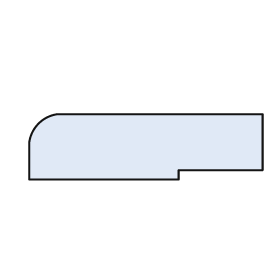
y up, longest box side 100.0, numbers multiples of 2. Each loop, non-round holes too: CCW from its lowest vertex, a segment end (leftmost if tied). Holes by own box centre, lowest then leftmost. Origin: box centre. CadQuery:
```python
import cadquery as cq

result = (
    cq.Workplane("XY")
    .moveTo(-50.0, -14.0)
    .lineTo(14.0, -14.0)
    .lineTo(14.0, -10.0)
    .lineTo(50.0, -10.0)
    .lineTo(50.0, 14.0)
    .lineTo(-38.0, 14.0)
    .threePointArc((-46.0, 10.0), (-50.0, 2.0))
    .close()
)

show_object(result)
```